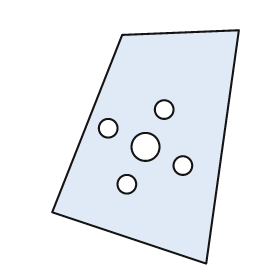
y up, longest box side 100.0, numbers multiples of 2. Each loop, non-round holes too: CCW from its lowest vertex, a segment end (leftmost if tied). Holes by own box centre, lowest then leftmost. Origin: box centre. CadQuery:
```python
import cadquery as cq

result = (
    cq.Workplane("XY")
    .moveTo(26.0, -50.0)
    .lineTo(40.0, 50.0)
    .lineTo(-10.0, 48.0)
    .lineTo(-40.0, -28.0)
    .close()
    .moveTo(-8.0, -16.0)
    .circle(4.0)
    .moveTo(16.0, -8.0)
    .circle(4.0)
    .moveTo(0.0, 0.0)
    .circle(6.0)
    .moveTo(-16.0, 8.0)
    .circle(4.0)
    .moveTo(8.0, 16.0)
    .circle(4.0)
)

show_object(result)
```